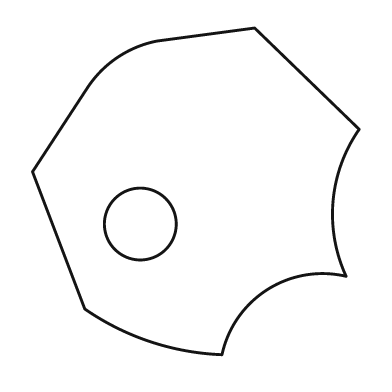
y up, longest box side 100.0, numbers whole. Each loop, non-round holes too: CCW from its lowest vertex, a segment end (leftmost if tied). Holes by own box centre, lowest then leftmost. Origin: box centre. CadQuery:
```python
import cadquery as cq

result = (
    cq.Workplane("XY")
    .moveTo(8.0, -50.0)
    .threePointArc((22.0, -30.0), (46.0, -26.0))
    .threePointArc((42.0, -3.0), (50.0, 19.0))
    .lineTo(18.0, 50.0)
    .lineTo(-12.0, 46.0)
    .threePointArc((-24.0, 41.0), (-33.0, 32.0))
    .lineTo(-50.0, 6.0)
    .lineTo(-34.0, -36.0)
    .threePointArc((-14.0, -46.0), (8.0, -50.0))
    .close()
    .moveTo(-17.0, -10.0)
    .circle(11.0)
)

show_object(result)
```